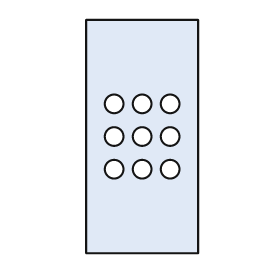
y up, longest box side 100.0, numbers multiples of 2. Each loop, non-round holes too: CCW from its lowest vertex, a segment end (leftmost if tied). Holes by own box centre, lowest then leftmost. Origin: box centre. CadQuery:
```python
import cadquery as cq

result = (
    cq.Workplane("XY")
    .moveTo(-24.0, -50.0)
    .lineTo(24.0, -50.0)
    .lineTo(24.0, 50.0)
    .lineTo(-24.0, 50.0)
    .close()
    .moveTo(-12.0, -14.0)
    .circle(4.0)
    .moveTo(0.0, -14.0)
    .circle(4.0)
    .moveTo(12.0, -14.0)
    .circle(4.0)
    .moveTo(-12.0, 0.0)
    .circle(4.0)
    .moveTo(0.0, 0.0)
    .circle(4.0)
    .moveTo(12.0, 0.0)
    .circle(4.0)
    .moveTo(-12.0, 14.0)
    .circle(4.0)
    .moveTo(0.0, 14.0)
    .circle(4.0)
    .moveTo(12.0, 14.0)
    .circle(4.0)
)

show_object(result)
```